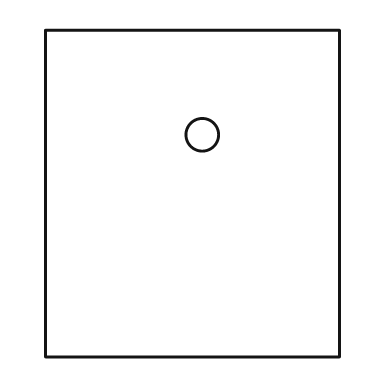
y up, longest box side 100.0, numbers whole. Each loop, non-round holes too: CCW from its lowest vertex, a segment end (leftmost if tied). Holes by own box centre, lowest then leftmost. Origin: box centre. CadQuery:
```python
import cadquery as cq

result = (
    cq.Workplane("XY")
    .moveTo(-45.0, -50.0)
    .lineTo(45.0, -50.0)
    .lineTo(45.0, 50.0)
    .lineTo(-45.0, 50.0)
    .close()
    .moveTo(3.0, 18.0)
    .circle(5.0)
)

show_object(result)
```